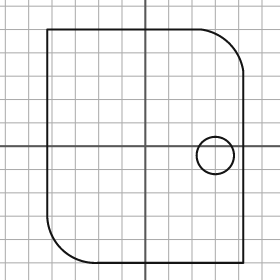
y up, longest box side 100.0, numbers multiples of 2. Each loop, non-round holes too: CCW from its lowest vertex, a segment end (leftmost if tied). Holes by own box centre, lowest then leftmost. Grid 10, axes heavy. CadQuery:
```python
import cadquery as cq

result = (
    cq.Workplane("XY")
    .moveTo(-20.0, -50.0)
    .lineTo(42.0, -50.0)
    .lineTo(42.0, 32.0)
    .threePointArc((36.0, 44.0), (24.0, 50.0))
    .lineTo(-42.0, 50.0)
    .lineTo(-42.0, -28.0)
    .threePointArc((-36.0, -44.0), (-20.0, -50.0))
    .close()
    .moveTo(30.0, -4.0)
    .circle(8.0)
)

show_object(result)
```